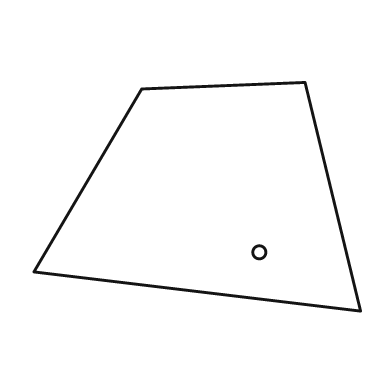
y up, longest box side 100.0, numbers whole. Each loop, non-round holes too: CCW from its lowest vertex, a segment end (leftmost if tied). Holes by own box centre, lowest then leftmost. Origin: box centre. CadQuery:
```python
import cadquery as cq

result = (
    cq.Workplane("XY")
    .moveTo(50.0, -35.0)
    .lineTo(33.0, 35.0)
    .lineTo(-17.0, 33.0)
    .lineTo(-50.0, -23.0)
    .close()
    .moveTo(19.0, -17.0)
    .circle(2.0)
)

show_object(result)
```